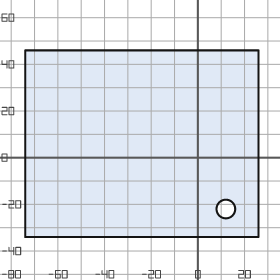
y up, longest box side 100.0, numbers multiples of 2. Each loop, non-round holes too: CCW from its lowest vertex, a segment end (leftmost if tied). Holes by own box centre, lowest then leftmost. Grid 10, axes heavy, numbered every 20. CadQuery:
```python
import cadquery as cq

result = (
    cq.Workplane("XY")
    .moveTo(-74.0, -34.0)
    .lineTo(26.0, -34.0)
    .lineTo(26.0, 46.0)
    .lineTo(-74.0, 46.0)
    .close()
    .moveTo(12.0, -22.0)
    .circle(4.0)
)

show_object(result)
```